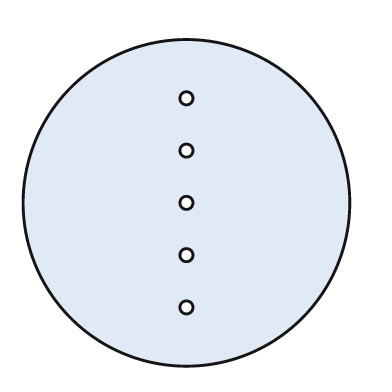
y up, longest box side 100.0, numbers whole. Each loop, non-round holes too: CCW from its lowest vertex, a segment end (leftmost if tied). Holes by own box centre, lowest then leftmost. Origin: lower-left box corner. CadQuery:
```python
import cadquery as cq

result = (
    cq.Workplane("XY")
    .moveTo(50.0, 50.0)
    .circle(50.0)
    .moveTo(50.0, 18.0)
    .circle(2.0)
    .moveTo(50.0, 34.0)
    .circle(2.0)
    .moveTo(50.0, 50.0)
    .circle(2.0)
    .moveTo(50.0, 66.0)
    .circle(2.0)
    .moveTo(50.0, 82.0)
    .circle(2.0)
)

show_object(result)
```